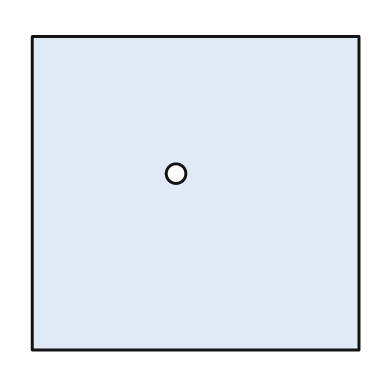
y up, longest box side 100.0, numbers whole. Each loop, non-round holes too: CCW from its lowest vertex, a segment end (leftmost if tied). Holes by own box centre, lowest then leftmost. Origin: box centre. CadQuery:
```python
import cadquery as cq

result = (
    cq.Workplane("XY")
    .moveTo(-50.0, -48.0)
    .lineTo(50.0, -48.0)
    .lineTo(50.0, 48.0)
    .lineTo(-50.0, 48.0)
    .close()
    .moveTo(-6.0, 6.0)
    .circle(3.0)
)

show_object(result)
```